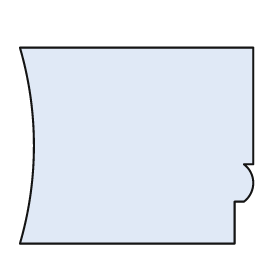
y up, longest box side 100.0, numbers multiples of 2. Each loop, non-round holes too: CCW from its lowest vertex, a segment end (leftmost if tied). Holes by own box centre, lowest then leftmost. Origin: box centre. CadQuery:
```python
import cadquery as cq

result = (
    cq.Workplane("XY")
    .moveTo(-50.0, -42.0)
    .lineTo(42.0, -42.0)
    .lineTo(42.0, -24.0)
    .lineTo(46.0, -24.0)
    .threePointArc((50.0, -16.0), (46.0, -8.0))
    .lineTo(50.0, -8.0)
    .lineTo(50.0, 42.0)
    .lineTo(-50.0, 42.0)
    .threePointArc((-44.0, 0.0), (-50.0, -42.0))
    .close()
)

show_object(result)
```